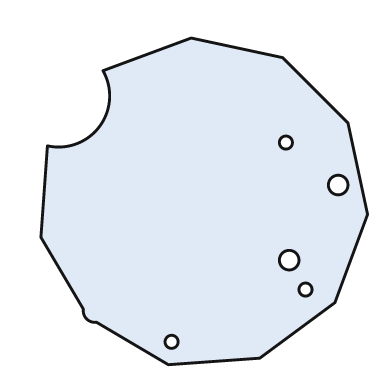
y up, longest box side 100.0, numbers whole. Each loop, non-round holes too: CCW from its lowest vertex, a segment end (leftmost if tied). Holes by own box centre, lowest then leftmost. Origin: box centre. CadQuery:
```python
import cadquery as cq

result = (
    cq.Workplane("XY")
    .moveTo(-11.0, -50.0)
    .lineTo(17.0, -48.0)
    .lineTo(40.0, -31.0)
    .lineTo(50.0, -4.0)
    .lineTo(44.0, 24.0)
    .lineTo(24.0, 44.0)
    .lineTo(-4.0, 50.0)
    .lineTo(-31.0, 40.0)
    .threePointArc((-32.0, 23.0), (-48.0, 17.0))
    .lineTo(-50.0, -11.0)
    .lineTo(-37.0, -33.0)
    .threePointArc((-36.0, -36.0), (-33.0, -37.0))
    .close()
    .moveTo(-10.0, -43.0)
    .circle(2.0)
    .moveTo(31.0, -27.0)
    .circle(2.0)
    .moveTo(26.0, -18.0)
    .circle(3.0)
    .moveTo(41.0, 5.0)
    .circle(3.0)
    .moveTo(25.0, 18.0)
    .circle(2.0)
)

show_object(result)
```